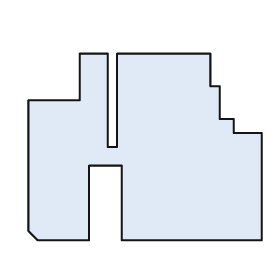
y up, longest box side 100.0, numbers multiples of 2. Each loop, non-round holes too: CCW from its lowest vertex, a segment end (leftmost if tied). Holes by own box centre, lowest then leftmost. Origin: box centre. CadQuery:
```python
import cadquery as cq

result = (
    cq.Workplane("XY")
    .moveTo(-46.0, -40.0)
    .lineTo(-24.0, -40.0)
    .lineTo(-24.0, -8.0)
    .lineTo(-10.0, -8.0)
    .lineTo(-10.0, -40.0)
    .lineTo(50.0, -40.0)
    .lineTo(50.0, 6.0)
    .lineTo(38.0, 6.0)
    .lineTo(38.0, 12.0)
    .lineTo(32.0, 12.0)
    .lineTo(32.0, 26.0)
    .lineTo(28.0, 26.0)
    .lineTo(28.0, 40.0)
    .lineTo(-12.0, 40.0)
    .lineTo(-12.0, 0.0)
    .lineTo(-16.0, 0.0)
    .lineTo(-16.0, 40.0)
    .lineTo(-28.0, 40.0)
    .lineTo(-28.0, 20.0)
    .lineTo(-50.0, 20.0)
    .lineTo(-50.0, -36.0)
    .close()
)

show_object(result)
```